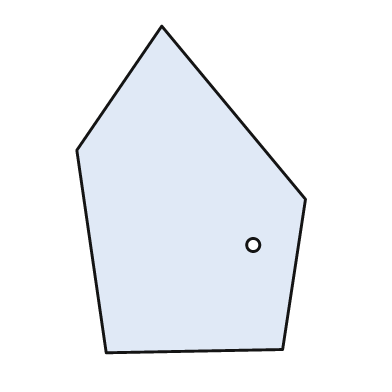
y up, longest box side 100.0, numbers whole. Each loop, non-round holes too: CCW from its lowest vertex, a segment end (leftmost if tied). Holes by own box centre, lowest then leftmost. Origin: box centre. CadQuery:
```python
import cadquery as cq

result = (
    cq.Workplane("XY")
    .moveTo(-26.0, -50.0)
    .lineTo(28.0, -49.0)
    .lineTo(35.0, -3.0)
    .lineTo(-9.0, 50.0)
    .lineTo(-35.0, 12.0)
    .close()
    .moveTo(19.0, -17.0)
    .circle(2.0)
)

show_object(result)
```